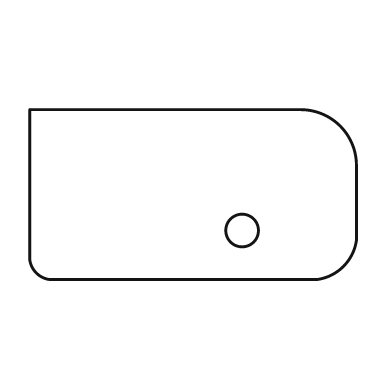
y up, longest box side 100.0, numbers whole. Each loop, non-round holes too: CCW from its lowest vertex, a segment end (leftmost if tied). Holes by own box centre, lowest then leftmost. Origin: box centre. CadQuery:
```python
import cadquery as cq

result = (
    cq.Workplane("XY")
    .moveTo(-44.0, -26.0)
    .lineTo(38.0, -26.0)
    .threePointArc((46.0, -22.0), (50.0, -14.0))
    .lineTo(50.0, 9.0)
    .threePointArc((45.0, 21.0), (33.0, 26.0))
    .lineTo(-50.0, 26.0)
    .lineTo(-50.0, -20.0)
    .threePointArc((-48.0, -24.0), (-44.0, -26.0))
    .close()
    .moveTo(15.0, -11.0)
    .circle(5.0)
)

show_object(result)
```